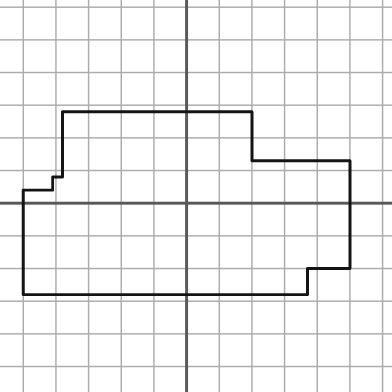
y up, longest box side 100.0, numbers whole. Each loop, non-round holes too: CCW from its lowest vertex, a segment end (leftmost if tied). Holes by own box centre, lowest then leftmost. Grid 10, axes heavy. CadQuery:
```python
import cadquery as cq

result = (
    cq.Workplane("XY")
    .moveTo(-50.0, -28.0)
    .lineTo(37.0, -28.0)
    .lineTo(37.0, -20.0)
    .lineTo(50.0, -20.0)
    .lineTo(50.0, 13.0)
    .lineTo(20.0, 13.0)
    .lineTo(20.0, 28.0)
    .lineTo(-38.0, 28.0)
    .lineTo(-38.0, 8.0)
    .lineTo(-41.0, 8.0)
    .lineTo(-41.0, 4.0)
    .lineTo(-50.0, 4.0)
    .close()
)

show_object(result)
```